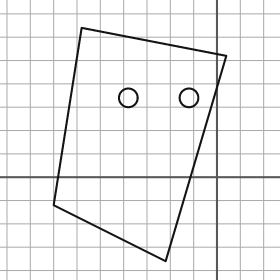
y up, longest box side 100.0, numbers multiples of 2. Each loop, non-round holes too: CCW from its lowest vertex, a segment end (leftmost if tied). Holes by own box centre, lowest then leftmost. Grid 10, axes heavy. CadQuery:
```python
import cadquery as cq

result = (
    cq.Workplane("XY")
    .moveTo(-22.0, -36.0)
    .lineTo(4.0, 52.0)
    .lineTo(-58.0, 64.0)
    .lineTo(-70.0, -12.0)
    .close()
    .moveTo(-38.0, 34.0)
    .circle(4.0)
    .moveTo(-12.0, 34.0)
    .circle(4.0)
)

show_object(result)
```